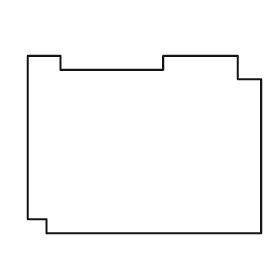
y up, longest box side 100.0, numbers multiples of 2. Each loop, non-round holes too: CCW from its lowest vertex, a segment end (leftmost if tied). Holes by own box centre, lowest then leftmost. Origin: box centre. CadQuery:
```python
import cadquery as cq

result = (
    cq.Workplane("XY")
    .moveTo(-42.0, -38.0)
    .lineTo(50.0, -38.0)
    .lineTo(50.0, 28.0)
    .lineTo(40.0, 28.0)
    .lineTo(40.0, 38.0)
    .lineTo(8.0, 38.0)
    .lineTo(8.0, 32.0)
    .lineTo(-36.0, 32.0)
    .lineTo(-36.0, 38.0)
    .lineTo(-50.0, 38.0)
    .lineTo(-50.0, -32.0)
    .lineTo(-42.0, -32.0)
    .close()
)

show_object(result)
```